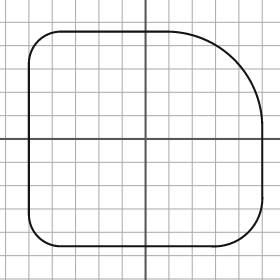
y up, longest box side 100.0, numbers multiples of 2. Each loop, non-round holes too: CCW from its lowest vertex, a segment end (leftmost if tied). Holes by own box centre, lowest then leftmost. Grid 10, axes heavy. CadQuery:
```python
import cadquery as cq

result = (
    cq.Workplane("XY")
    .moveTo(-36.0, -46.0)
    .lineTo(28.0, -46.0)
    .threePointArc((44.0, -40.0), (50.0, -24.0))
    .lineTo(50.0, 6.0)
    .threePointArc((38.0, 34.0), (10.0, 46.0))
    .lineTo(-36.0, 46.0)
    .threePointArc((-46.0, 42.0), (-50.0, 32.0))
    .lineTo(-50.0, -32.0)
    .threePointArc((-46.0, -42.0), (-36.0, -46.0))
    .close()
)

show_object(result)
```